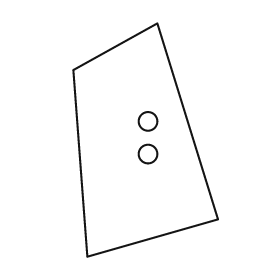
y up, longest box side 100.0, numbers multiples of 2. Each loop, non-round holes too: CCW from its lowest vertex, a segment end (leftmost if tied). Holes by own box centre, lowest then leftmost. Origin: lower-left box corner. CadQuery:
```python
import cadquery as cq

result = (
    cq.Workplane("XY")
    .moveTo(6.0, 0.0)
    .lineTo(62.0, 16.0)
    .lineTo(36.0, 100.0)
    .lineTo(0.0, 80.0)
    .close()
    .moveTo(32.0, 44.0)
    .circle(4.0)
    .moveTo(32.0, 58.0)
    .circle(4.0)
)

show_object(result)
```